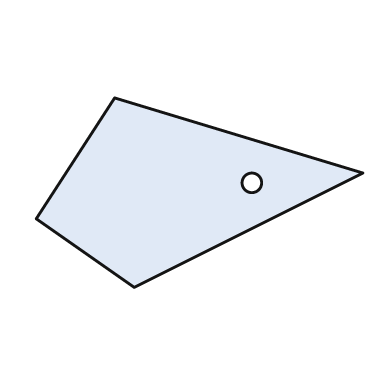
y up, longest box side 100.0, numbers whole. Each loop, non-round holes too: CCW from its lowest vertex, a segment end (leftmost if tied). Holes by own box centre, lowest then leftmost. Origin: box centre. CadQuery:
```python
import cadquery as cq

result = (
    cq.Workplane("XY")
    .moveTo(-20.0, -29.0)
    .lineTo(50.0, 6.0)
    .lineTo(-26.0, 29.0)
    .lineTo(-50.0, -8.0)
    .close()
    .moveTo(16.0, 3.0)
    .circle(3.0)
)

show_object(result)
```